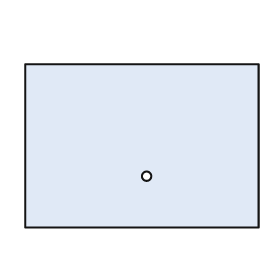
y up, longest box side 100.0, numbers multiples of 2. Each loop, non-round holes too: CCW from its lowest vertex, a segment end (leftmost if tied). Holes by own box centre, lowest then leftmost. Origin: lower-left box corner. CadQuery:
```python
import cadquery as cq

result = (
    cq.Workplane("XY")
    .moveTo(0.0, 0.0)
    .lineTo(100.0, 0.0)
    .lineTo(100.0, 70.0)
    .lineTo(0.0, 70.0)
    .close()
    .moveTo(52.0, 22.0)
    .circle(2.0)
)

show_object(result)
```